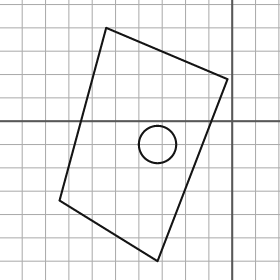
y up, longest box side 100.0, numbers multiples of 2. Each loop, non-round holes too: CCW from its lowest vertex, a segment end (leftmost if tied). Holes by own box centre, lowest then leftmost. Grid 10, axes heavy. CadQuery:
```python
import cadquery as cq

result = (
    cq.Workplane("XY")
    .moveTo(-32.0, -60.0)
    .lineTo(-2.0, 18.0)
    .lineTo(-54.0, 40.0)
    .lineTo(-74.0, -34.0)
    .close()
    .moveTo(-32.0, -10.0)
    .circle(8.0)
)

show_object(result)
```